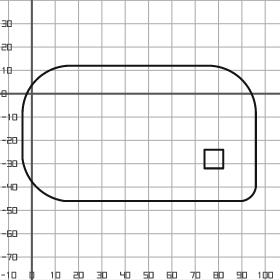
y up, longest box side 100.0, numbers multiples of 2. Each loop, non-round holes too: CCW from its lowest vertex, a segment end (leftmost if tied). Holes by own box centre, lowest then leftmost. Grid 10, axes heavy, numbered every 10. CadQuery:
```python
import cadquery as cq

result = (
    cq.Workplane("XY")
    .moveTo(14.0, -46.0)
    .lineTo(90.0, -46.0)
    .threePointArc((94.0, -44.0), (96.0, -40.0))
    .lineTo(96.0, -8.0)
    .threePointArc((90.0, 6.0), (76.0, 12.0))
    .lineTo(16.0, 12.0)
    .threePointArc((2.0, 6.0), (-4.0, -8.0))
    .lineTo(-4.0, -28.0)
    .threePointArc((2.0, -40.0), (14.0, -46.0))
    .close()
    .moveTo(74.0, -32.0)
    .lineTo(82.0, -32.0)
    .lineTo(82.0, -24.0)
    .lineTo(74.0, -24.0)
    .close()
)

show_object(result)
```